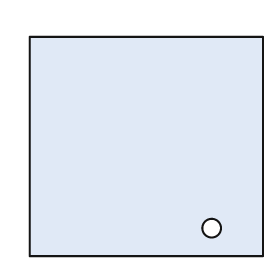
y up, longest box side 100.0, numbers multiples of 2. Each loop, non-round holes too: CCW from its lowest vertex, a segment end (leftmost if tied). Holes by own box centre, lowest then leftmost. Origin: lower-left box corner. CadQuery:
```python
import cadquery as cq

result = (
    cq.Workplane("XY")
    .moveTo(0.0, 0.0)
    .lineTo(100.0, 0.0)
    .lineTo(100.0, 94.0)
    .lineTo(0.0, 94.0)
    .close()
    .moveTo(78.0, 12.0)
    .circle(4.0)
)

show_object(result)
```